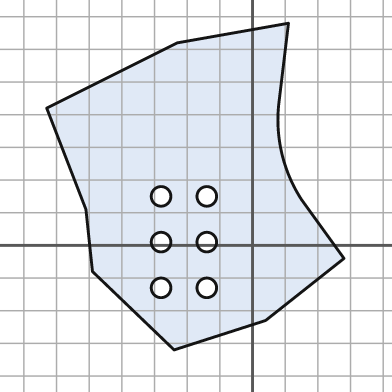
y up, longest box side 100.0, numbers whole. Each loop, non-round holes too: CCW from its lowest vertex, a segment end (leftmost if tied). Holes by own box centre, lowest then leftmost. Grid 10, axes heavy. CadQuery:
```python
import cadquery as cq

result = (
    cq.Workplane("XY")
    .moveTo(-24.0, -32.0)
    .lineTo(4.0, -23.0)
    .lineTo(28.0, -4.0)
    .lineTo(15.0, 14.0)
    .threePointArc((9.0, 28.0), (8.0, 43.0))
    .lineTo(11.0, 68.0)
    .lineTo(-23.0, 62.0)
    .lineTo(-63.0, 42.0)
    .lineTo(-51.0, 11.0)
    .lineTo(-49.0, -8.0)
    .close()
    .moveTo(-28.0, -13.0)
    .circle(3.0)
    .moveTo(-14.0, -13.0)
    .circle(3.0)
    .moveTo(-28.0, 1.0)
    .circle(3.0)
    .moveTo(-14.0, 1.0)
    .circle(3.0)
    .moveTo(-28.0, 15.0)
    .circle(3.0)
    .moveTo(-14.0, 15.0)
    .circle(3.0)
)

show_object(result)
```